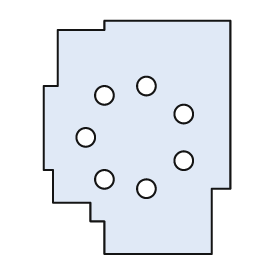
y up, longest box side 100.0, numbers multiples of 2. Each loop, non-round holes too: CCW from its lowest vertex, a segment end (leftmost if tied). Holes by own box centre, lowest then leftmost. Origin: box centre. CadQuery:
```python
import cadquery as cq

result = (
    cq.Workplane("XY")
    .moveTo(-14.0, -50.0)
    .lineTo(32.0, -50.0)
    .lineTo(32.0, -22.0)
    .lineTo(40.0, -22.0)
    .lineTo(40.0, 50.0)
    .lineTo(-14.0, 50.0)
    .lineTo(-14.0, 46.0)
    .lineTo(-34.0, 46.0)
    .lineTo(-34.0, 22.0)
    .lineTo(-40.0, 22.0)
    .lineTo(-40.0, -14.0)
    .lineTo(-36.0, -14.0)
    .lineTo(-36.0, -28.0)
    .lineTo(-20.0, -28.0)
    .lineTo(-20.0, -36.0)
    .lineTo(-14.0, -36.0)
    .close()
    .moveTo(4.0, -22.0)
    .circle(4.0)
    .moveTo(-14.0, -18.0)
    .circle(4.0)
    .moveTo(20.0, -10.0)
    .circle(4.0)
    .moveTo(-22.0, 0.0)
    .circle(4.0)
    .moveTo(20.0, 10.0)
    .circle(4.0)
    .moveTo(-14.0, 18.0)
    .circle(4.0)
    .moveTo(4.0, 22.0)
    .circle(4.0)
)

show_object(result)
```